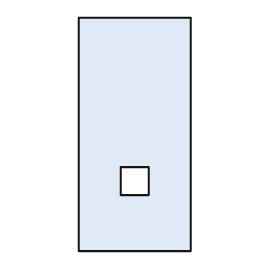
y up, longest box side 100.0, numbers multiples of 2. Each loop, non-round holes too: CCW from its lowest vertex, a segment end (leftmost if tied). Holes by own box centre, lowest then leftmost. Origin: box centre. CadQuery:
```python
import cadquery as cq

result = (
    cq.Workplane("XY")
    .moveTo(-24.0, -50.0)
    .lineTo(24.0, -50.0)
    .lineTo(24.0, 50.0)
    .lineTo(-24.0, 50.0)
    .close()
    .moveTo(-6.0, -26.0)
    .lineTo(6.0, -26.0)
    .lineTo(6.0, -14.0)
    .lineTo(-6.0, -14.0)
    .close()
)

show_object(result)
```